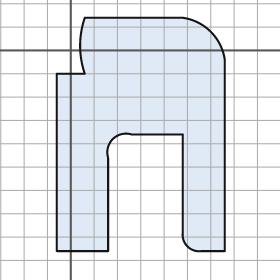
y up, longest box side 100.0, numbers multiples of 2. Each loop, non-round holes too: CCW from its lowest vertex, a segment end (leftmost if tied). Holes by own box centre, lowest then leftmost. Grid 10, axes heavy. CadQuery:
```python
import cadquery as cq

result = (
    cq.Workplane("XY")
    .moveTo(-6.0, -86.0)
    .lineTo(16.0, -86.0)
    .lineTo(16.0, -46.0)
    .threePointArc((18.0, -38.0), (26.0, -36.0))
    .lineTo(48.0, -36.0)
    .lineTo(48.0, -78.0)
    .threePointArc((50.0, -84.0), (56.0, -86.0))
    .lineTo(66.0, -86.0)
    .lineTo(66.0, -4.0)
    .threePointArc((60.0, 8.0), (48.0, 14.0))
    .lineTo(6.0, 14.0)
    .threePointArc((4.0, 2.0), (6.0, -10.0))
    .lineTo(-6.0, -10.0)
    .close()
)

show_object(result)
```